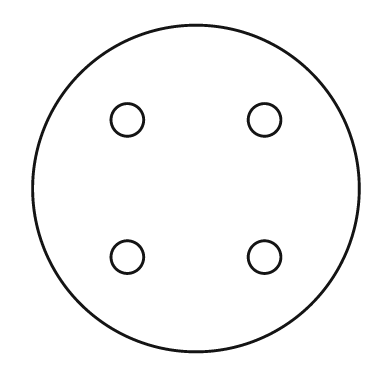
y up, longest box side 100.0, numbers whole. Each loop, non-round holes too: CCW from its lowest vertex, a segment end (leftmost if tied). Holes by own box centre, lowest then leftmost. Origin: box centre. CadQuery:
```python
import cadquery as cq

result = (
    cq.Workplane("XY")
    .moveTo(0.0, 0.0)
    .circle(50.0)
    .moveTo(-21.0, -21.0)
    .circle(5.0)
    .moveTo(21.0, -21.0)
    .circle(5.0)
    .moveTo(-21.0, 21.0)
    .circle(5.0)
    .moveTo(21.0, 21.0)
    .circle(5.0)
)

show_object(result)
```